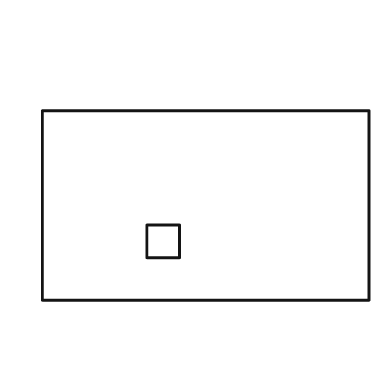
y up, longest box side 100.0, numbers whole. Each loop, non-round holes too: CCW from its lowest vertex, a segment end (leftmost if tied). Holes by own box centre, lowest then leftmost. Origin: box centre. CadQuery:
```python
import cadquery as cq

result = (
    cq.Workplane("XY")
    .moveTo(-50.0, -29.0)
    .lineTo(50.0, -29.0)
    .lineTo(50.0, 29.0)
    .lineTo(-50.0, 29.0)
    .close()
    .moveTo(-18.0, -16.0)
    .lineTo(-8.0, -16.0)
    .lineTo(-8.0, -6.0)
    .lineTo(-18.0, -6.0)
    .close()
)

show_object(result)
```